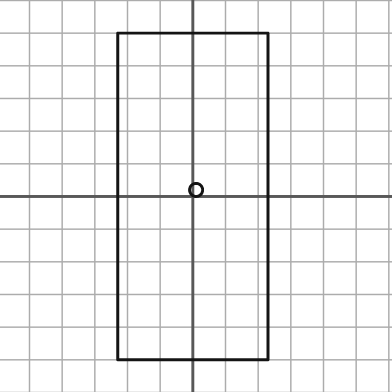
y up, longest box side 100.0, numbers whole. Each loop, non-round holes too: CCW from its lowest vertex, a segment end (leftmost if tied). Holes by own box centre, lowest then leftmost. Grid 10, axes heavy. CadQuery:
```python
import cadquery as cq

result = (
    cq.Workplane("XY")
    .moveTo(-23.0, -50.0)
    .lineTo(23.0, -50.0)
    .lineTo(23.0, 50.0)
    .lineTo(-23.0, 50.0)
    .close()
    .moveTo(1.0, 2.0)
    .circle(2.0)
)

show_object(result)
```